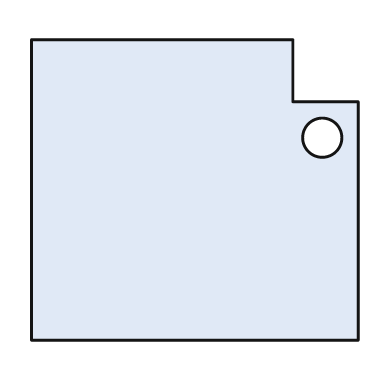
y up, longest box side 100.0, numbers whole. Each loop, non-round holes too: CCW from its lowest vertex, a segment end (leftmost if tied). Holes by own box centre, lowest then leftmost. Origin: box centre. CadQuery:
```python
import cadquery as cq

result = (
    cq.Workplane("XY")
    .moveTo(-50.0, -46.0)
    .lineTo(50.0, -46.0)
    .lineTo(50.0, 27.0)
    .lineTo(30.0, 27.0)
    .lineTo(30.0, 46.0)
    .lineTo(-50.0, 46.0)
    .close()
    .moveTo(39.0, 16.0)
    .circle(6.0)
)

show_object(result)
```